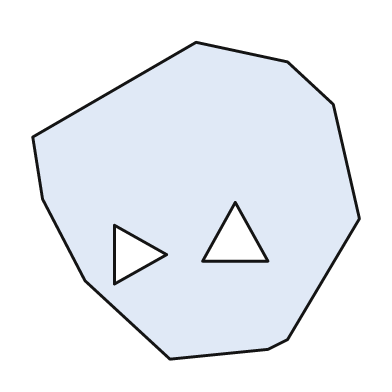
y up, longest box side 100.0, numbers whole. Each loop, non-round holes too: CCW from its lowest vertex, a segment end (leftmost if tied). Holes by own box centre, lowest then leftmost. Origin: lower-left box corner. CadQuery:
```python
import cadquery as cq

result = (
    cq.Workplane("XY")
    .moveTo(42.0, 0.0)
    .lineTo(72.0, 3.0)
    .lineTo(78.0, 6.0)
    .lineTo(100.0, 43.0)
    .lineTo(92.0, 78.0)
    .lineTo(78.0, 91.0)
    .lineTo(50.0, 97.0)
    .lineTo(0.0, 68.0)
    .lineTo(3.0, 49.0)
    .lineTo(16.0, 24.0)
    .close()
    .moveTo(25.0, 23.0)
    .lineTo(41.0, 32.0)
    .lineTo(25.0, 41.0)
    .close()
    .moveTo(52.0, 30.0)
    .lineTo(72.0, 30.0)
    .lineTo(62.0, 48.0)
    .close()
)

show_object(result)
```